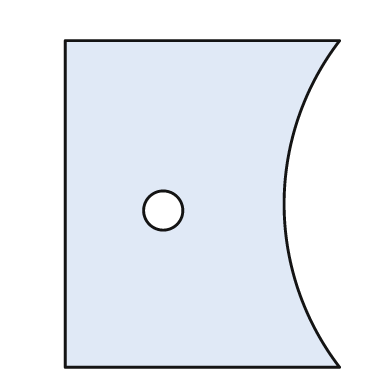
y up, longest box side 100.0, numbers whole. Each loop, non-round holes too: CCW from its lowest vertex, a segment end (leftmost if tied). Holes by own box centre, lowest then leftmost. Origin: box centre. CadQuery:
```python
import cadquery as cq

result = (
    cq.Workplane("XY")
    .moveTo(-42.0, -50.0)
    .lineTo(42.0, -50.0)
    .threePointArc((25.0, 0.0), (42.0, 50.0))
    .lineTo(-42.0, 50.0)
    .close()
    .moveTo(-12.0, -2.0)
    .circle(6.0)
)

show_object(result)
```